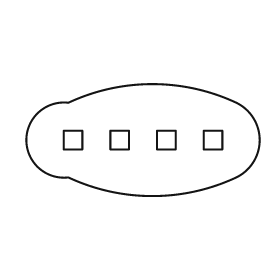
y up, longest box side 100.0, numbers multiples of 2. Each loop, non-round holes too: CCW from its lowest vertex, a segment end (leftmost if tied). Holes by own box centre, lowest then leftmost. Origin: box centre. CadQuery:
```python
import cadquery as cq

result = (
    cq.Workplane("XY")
    .moveTo(-32.0, -16.0)
    .threePointArc((4.0, -24.0), (40.0, -16.0))
    .threePointArc((50.0, 0.0), (40.0, 16.0))
    .threePointArc((4.0, 24.0), (-32.0, 16.0))
    .threePointArc((-50.0, 0.0), (-32.0, -16.0))
    .close()
    .moveTo(-34.0, -4.0)
    .lineTo(-26.0, -4.0)
    .lineTo(-26.0, 4.0)
    .lineTo(-34.0, 4.0)
    .close()
    .moveTo(-14.0, -4.0)
    .lineTo(-6.0, -4.0)
    .lineTo(-6.0, 4.0)
    .lineTo(-14.0, 4.0)
    .close()
    .moveTo(6.0, -4.0)
    .lineTo(14.0, -4.0)
    .lineTo(14.0, 4.0)
    .lineTo(6.0, 4.0)
    .close()
    .moveTo(26.0, -4.0)
    .lineTo(34.0, -4.0)
    .lineTo(34.0, 4.0)
    .lineTo(26.0, 4.0)
    .close()
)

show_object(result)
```